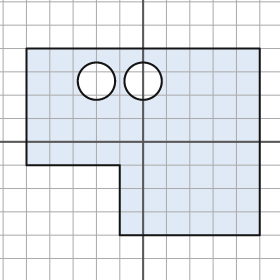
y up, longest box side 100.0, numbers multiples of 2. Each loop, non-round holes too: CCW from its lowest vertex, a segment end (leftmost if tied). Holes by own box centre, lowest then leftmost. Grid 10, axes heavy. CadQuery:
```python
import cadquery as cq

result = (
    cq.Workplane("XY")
    .moveTo(-10.0, -40.0)
    .lineTo(50.0, -40.0)
    .lineTo(50.0, 40.0)
    .lineTo(-50.0, 40.0)
    .lineTo(-50.0, -10.0)
    .lineTo(-10.0, -10.0)
    .close()
    .moveTo(-20.0, 26.0)
    .circle(8.0)
    .moveTo(0.0, 26.0)
    .circle(8.0)
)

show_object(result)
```